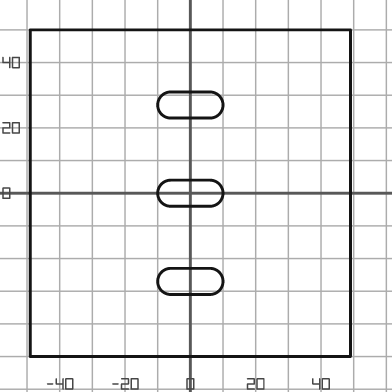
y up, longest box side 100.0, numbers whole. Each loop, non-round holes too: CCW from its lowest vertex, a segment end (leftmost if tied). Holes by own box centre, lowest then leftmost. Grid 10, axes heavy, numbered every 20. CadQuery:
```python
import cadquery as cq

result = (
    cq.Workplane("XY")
    .moveTo(-49.0, -50.0)
    .lineTo(49.0, -50.0)
    .lineTo(49.0, 50.0)
    .lineTo(-49.0, 50.0)
    .close()
    .moveTo(-6.0, -31.0)
    .lineTo(6.0, -31.0)
    .threePointArc((10.0, -27.0), (6.0, -23.0))
    .lineTo(-6.0, -23.0)
    .threePointArc((-10.0, -27.0), (-6.0, -31.0))
    .close()
    .moveTo(-6.0, -4.0)
    .lineTo(6.0, -4.0)
    .threePointArc((10.0, 0.0), (6.0, 4.0))
    .lineTo(-6.0, 4.0)
    .threePointArc((-10.0, 0.0), (-6.0, -4.0))
    .close()
    .moveTo(-6.0, 23.0)
    .lineTo(6.0, 23.0)
    .threePointArc((10.0, 27.0), (6.0, 31.0))
    .lineTo(-6.0, 31.0)
    .threePointArc((-10.0, 27.0), (-6.0, 23.0))
    .close()
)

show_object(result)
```